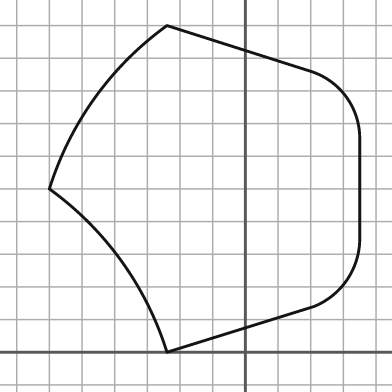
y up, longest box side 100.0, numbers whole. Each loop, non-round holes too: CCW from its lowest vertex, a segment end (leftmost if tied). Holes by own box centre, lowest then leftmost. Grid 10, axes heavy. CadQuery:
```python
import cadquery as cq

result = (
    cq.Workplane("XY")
    .moveTo(-24.0, 0.0)
    .lineTo(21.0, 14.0)
    .threePointArc((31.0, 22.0), (35.0, 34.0))
    .lineTo(35.0, 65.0)
    .threePointArc((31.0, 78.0), (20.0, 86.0))
    .lineTo(-24.0, 100.0)
    .threePointArc((-46.0, 78.0), (-60.0, 50.0))
    .threePointArc((-38.0, 28.0), (-24.0, 0.0))
    .close()
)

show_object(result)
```